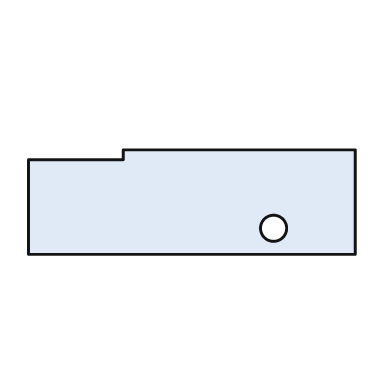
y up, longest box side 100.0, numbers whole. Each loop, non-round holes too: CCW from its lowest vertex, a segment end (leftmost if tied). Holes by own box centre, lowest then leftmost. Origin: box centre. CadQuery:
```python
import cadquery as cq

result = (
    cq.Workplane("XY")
    .moveTo(-50.0, -16.0)
    .lineTo(50.0, -16.0)
    .lineTo(50.0, 16.0)
    .lineTo(-21.0, 16.0)
    .lineTo(-21.0, 13.0)
    .lineTo(-50.0, 13.0)
    .close()
    .moveTo(25.0, -8.0)
    .circle(4.0)
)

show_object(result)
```